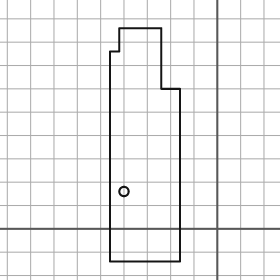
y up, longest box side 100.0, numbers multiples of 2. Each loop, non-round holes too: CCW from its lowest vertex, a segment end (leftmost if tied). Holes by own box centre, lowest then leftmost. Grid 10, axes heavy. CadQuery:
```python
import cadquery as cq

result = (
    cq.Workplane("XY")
    .moveTo(-46.0, -14.0)
    .lineTo(-16.0, -14.0)
    .lineTo(-16.0, 60.0)
    .lineTo(-24.0, 60.0)
    .lineTo(-24.0, 86.0)
    .lineTo(-42.0, 86.0)
    .lineTo(-42.0, 76.0)
    .lineTo(-46.0, 76.0)
    .close()
    .moveTo(-40.0, 16.0)
    .circle(2.0)
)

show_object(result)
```